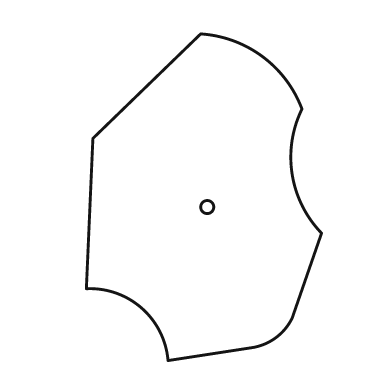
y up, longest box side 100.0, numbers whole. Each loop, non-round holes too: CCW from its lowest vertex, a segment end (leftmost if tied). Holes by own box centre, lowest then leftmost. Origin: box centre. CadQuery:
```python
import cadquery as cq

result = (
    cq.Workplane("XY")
    .moveTo(-11.0, -50.0)
    .lineTo(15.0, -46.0)
    .threePointArc((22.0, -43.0), (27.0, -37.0))
    .lineTo(36.0, -11.0)
    .threePointArc((27.0, 7.0), (30.0, 27.0))
    .threePointArc((18.0, 43.0), (-1.0, 50.0))
    .lineTo(-34.0, 18.0)
    .lineTo(-36.0, -28.0)
    .threePointArc((-19.0, -34.0), (-11.0, -50.0))
    .close()
    .moveTo(1.0, -3.0)
    .circle(2.0)
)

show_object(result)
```